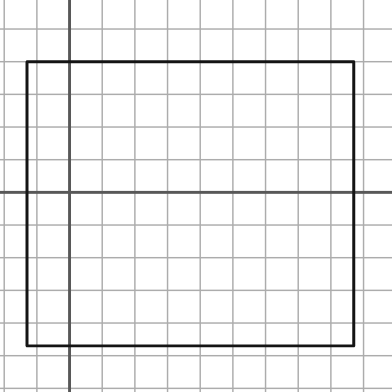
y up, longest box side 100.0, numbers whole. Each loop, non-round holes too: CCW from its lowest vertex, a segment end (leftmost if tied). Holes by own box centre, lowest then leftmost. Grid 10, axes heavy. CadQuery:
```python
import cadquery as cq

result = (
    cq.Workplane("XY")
    .moveTo(-13.0, -47.0)
    .lineTo(87.0, -47.0)
    .lineTo(87.0, 40.0)
    .lineTo(-13.0, 40.0)
    .close()
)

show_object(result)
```